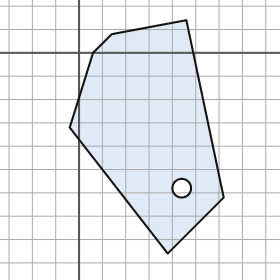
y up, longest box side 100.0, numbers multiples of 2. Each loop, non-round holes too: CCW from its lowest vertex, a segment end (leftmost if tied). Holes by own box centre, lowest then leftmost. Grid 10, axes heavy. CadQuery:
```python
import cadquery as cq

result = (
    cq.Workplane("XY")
    .moveTo(38.0, -86.0)
    .lineTo(62.0, -62.0)
    .lineTo(46.0, 14.0)
    .lineTo(14.0, 8.0)
    .lineTo(6.0, 0.0)
    .lineTo(-4.0, -32.0)
    .close()
    .moveTo(44.0, -58.0)
    .circle(4.0)
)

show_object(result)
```